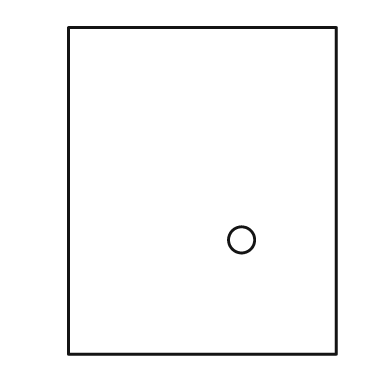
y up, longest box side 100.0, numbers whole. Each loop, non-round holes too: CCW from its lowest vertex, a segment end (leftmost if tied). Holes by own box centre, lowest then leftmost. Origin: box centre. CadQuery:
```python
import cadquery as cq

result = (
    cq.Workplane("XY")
    .moveTo(-41.0, -50.0)
    .lineTo(41.0, -50.0)
    .lineTo(41.0, 50.0)
    .lineTo(-41.0, 50.0)
    .close()
    .moveTo(12.0, -15.0)
    .circle(4.0)
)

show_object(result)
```